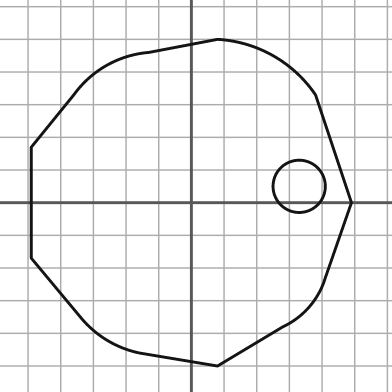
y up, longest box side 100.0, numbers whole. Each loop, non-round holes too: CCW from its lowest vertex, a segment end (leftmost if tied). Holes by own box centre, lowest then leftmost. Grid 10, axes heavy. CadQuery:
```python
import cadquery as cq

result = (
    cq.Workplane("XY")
    .moveTo(8.0, -50.0)
    .lineTo(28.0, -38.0)
    .threePointArc((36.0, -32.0), (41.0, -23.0))
    .lineTo(49.0, 0.0)
    .lineTo(38.0, 33.0)
    .threePointArc((25.0, 45.0), (8.0, 50.0))
    .lineTo(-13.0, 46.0)
    .threePointArc((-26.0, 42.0), (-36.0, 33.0))
    .lineTo(-49.0, 17.0)
    .lineTo(-49.0, -17.0)
    .lineTo(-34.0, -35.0)
    .threePointArc((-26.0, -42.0), (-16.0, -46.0))
    .close()
    .moveTo(33.0, 5.0)
    .circle(8.0)
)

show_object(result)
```